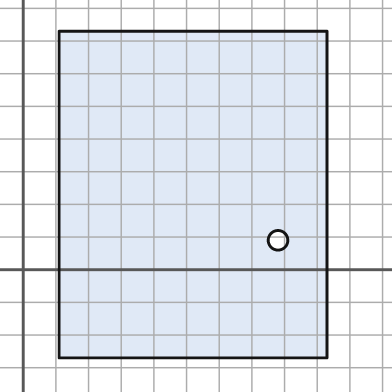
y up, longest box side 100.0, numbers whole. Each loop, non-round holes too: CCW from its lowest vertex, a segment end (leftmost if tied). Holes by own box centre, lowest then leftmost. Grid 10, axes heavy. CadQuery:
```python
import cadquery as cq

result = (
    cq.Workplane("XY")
    .moveTo(11.0, -27.0)
    .lineTo(93.0, -27.0)
    .lineTo(93.0, 73.0)
    .lineTo(11.0, 73.0)
    .close()
    .moveTo(78.0, 9.0)
    .circle(3.0)
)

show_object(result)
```